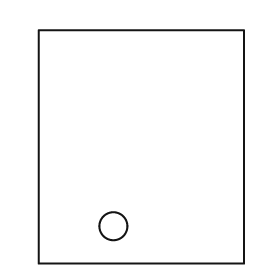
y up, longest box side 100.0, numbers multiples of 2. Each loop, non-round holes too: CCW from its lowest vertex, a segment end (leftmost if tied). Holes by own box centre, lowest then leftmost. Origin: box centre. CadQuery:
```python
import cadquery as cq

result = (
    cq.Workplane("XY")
    .moveTo(-44.0, -50.0)
    .lineTo(44.0, -50.0)
    .lineTo(44.0, 50.0)
    .lineTo(-44.0, 50.0)
    .close()
    .moveTo(-12.0, -34.0)
    .circle(6.0)
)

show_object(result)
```